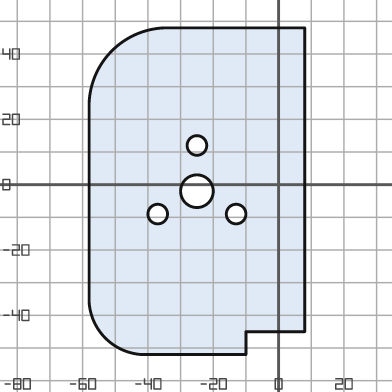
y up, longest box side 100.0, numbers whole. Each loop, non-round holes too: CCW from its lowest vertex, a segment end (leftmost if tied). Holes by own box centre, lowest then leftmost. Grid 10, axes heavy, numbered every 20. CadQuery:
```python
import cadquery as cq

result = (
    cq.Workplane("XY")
    .moveTo(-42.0, -52.0)
    .lineTo(-10.0, -52.0)
    .lineTo(-10.0, -45.0)
    .lineTo(8.0, -45.0)
    .lineTo(8.0, 48.0)
    .lineTo(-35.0, 48.0)
    .threePointArc((-51.0, 41.0), (-58.0, 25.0))
    .lineTo(-58.0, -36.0)
    .threePointArc((-53.0, -47.0), (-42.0, -52.0))
    .close()
    .moveTo(-37.0, -9.0)
    .circle(3.0)
    .moveTo(-13.0, -9.0)
    .circle(3.0)
    .moveTo(-25.0, -2.0)
    .circle(5.0)
    .moveTo(-25.0, 12.0)
    .circle(3.0)
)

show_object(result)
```